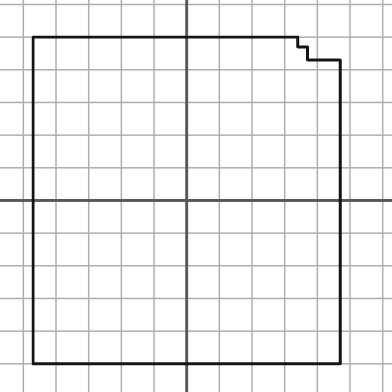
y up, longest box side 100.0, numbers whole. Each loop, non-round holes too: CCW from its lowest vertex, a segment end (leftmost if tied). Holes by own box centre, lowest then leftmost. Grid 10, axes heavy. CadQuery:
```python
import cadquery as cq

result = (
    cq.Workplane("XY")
    .moveTo(-47.0, -50.0)
    .lineTo(47.0, -50.0)
    .lineTo(47.0, 43.0)
    .lineTo(37.0, 43.0)
    .lineTo(37.0, 47.0)
    .lineTo(34.0, 47.0)
    .lineTo(34.0, 50.0)
    .lineTo(-47.0, 50.0)
    .close()
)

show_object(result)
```